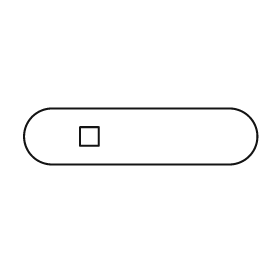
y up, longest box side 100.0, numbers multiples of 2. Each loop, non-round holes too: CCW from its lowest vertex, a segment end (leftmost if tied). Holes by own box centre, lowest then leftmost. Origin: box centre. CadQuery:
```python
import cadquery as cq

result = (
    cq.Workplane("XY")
    .moveTo(-38.0, -12.0)
    .lineTo(38.0, -12.0)
    .threePointArc((50.0, 0.0), (38.0, 12.0))
    .lineTo(-38.0, 12.0)
    .threePointArc((-50.0, 0.0), (-38.0, -12.0))
    .close()
    .moveTo(-26.0, -4.0)
    .lineTo(-18.0, -4.0)
    .lineTo(-18.0, 4.0)
    .lineTo(-26.0, 4.0)
    .close()
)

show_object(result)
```